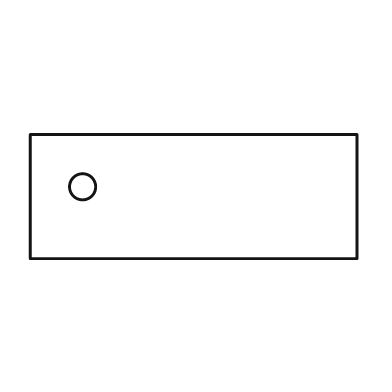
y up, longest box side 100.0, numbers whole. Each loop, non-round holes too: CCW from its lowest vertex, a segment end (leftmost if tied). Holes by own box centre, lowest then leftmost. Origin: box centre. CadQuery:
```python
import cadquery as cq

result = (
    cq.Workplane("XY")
    .moveTo(-50.0, -19.0)
    .lineTo(50.0, -19.0)
    .lineTo(50.0, 19.0)
    .lineTo(-50.0, 19.0)
    .close()
    .moveTo(-34.0, 3.0)
    .circle(4.0)
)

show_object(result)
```